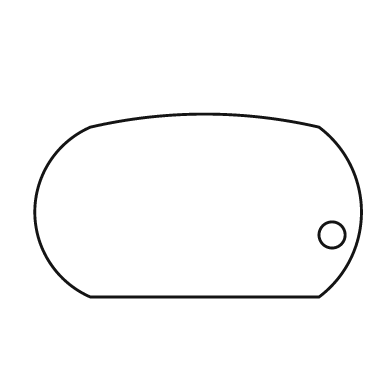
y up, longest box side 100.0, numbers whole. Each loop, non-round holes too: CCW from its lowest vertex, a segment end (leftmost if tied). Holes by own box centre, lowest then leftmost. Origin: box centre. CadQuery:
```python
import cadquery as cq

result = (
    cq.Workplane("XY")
    .moveTo(-33.0, -28.0)
    .lineTo(37.0, -28.0)
    .threePointArc((50.0, -2.0), (37.0, 24.0))
    .threePointArc((2.0, 28.0), (-33.0, 24.0))
    .threePointArc((-50.0, -2.0), (-33.0, -28.0))
    .close()
    .moveTo(41.0, -9.0)
    .circle(4.0)
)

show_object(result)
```